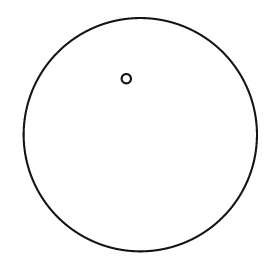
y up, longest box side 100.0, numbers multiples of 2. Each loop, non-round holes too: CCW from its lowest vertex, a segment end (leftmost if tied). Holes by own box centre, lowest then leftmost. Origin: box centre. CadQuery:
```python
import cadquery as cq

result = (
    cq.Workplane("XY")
    .moveTo(0.0, 0.0)
    .circle(50.0)
    .moveTo(-6.0, 24.0)
    .circle(2.0)
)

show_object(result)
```